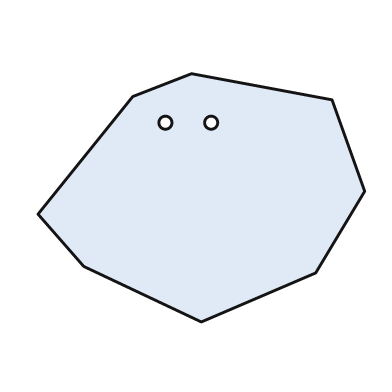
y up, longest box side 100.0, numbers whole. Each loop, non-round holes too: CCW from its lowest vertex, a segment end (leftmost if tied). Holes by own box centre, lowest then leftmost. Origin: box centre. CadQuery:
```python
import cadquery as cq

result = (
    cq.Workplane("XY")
    .moveTo(0.0, -38.0)
    .lineTo(35.0, -23.0)
    .lineTo(50.0, 2.0)
    .lineTo(40.0, 30.0)
    .lineTo(-3.0, 38.0)
    .lineTo(-21.0, 31.0)
    .lineTo(-50.0, -5.0)
    .lineTo(-36.0, -21.0)
    .close()
    .moveTo(-11.0, 23.0)
    .circle(2.0)
    .moveTo(3.0, 23.0)
    .circle(2.0)
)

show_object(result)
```